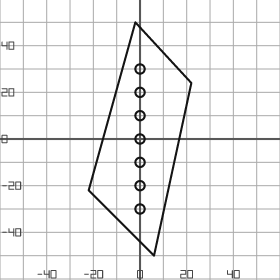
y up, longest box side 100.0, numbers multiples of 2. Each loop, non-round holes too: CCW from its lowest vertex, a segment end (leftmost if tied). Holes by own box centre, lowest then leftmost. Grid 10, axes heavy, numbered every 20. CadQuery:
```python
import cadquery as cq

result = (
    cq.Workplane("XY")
    .moveTo(6.0, -50.0)
    .lineTo(22.0, 24.0)
    .lineTo(-2.0, 50.0)
    .lineTo(-22.0, -22.0)
    .close()
    .moveTo(0.0, -30.0)
    .circle(2.0)
    .moveTo(0.0, -20.0)
    .circle(2.0)
    .moveTo(0.0, -10.0)
    .circle(2.0)
    .moveTo(0.0, 0.0)
    .circle(2.0)
    .moveTo(0.0, 10.0)
    .circle(2.0)
    .moveTo(0.0, 20.0)
    .circle(2.0)
    .moveTo(0.0, 30.0)
    .circle(2.0)
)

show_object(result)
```